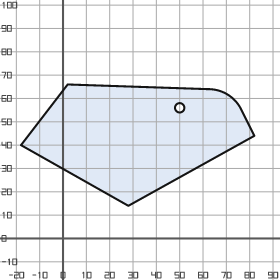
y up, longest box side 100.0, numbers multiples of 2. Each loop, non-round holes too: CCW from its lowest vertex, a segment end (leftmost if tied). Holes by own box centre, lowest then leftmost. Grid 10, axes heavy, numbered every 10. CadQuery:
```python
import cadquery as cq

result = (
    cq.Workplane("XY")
    .moveTo(28.0, 14.0)
    .lineTo(82.0, 44.0)
    .lineTo(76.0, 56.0)
    .threePointArc((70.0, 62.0), (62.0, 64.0))
    .lineTo(2.0, 66.0)
    .lineTo(-18.0, 40.0)
    .close()
    .moveTo(50.0, 56.0)
    .circle(2.0)
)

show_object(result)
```